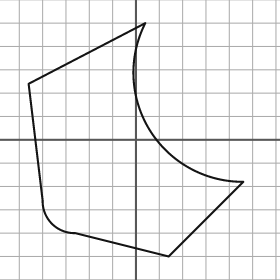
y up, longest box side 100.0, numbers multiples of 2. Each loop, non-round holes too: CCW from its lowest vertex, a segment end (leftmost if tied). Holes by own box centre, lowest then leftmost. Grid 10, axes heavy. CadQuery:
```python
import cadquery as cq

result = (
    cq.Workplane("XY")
    .moveTo(14.0, -50.0)
    .lineTo(46.0, -18.0)
    .threePointArc((6.0, 4.0), (4.0, 50.0))
    .lineTo(-46.0, 24.0)
    .lineTo(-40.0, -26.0)
    .threePointArc((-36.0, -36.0), (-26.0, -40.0))
    .close()
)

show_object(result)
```